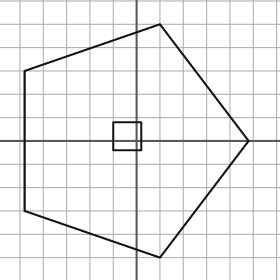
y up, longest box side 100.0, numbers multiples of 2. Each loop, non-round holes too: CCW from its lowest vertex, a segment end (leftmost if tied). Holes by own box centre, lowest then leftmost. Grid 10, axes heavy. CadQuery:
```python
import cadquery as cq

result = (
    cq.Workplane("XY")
    .moveTo(10.0, -50.0)
    .lineTo(48.0, 0.0)
    .lineTo(10.0, 50.0)
    .lineTo(-48.0, 30.0)
    .lineTo(-48.0, -30.0)
    .close()
    .moveTo(-10.0, -4.0)
    .lineTo(2.0, -4.0)
    .lineTo(2.0, 8.0)
    .lineTo(-10.0, 8.0)
    .close()
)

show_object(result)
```